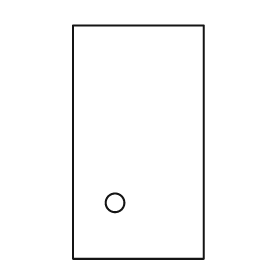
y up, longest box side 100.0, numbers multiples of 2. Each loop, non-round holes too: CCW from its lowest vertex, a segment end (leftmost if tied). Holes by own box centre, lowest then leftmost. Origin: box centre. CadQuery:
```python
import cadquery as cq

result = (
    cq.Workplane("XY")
    .moveTo(-28.0, -50.0)
    .lineTo(28.0, -50.0)
    .lineTo(28.0, 50.0)
    .lineTo(-28.0, 50.0)
    .close()
    .moveTo(-10.0, -26.0)
    .circle(4.0)
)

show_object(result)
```